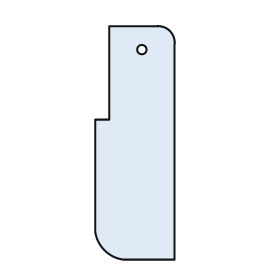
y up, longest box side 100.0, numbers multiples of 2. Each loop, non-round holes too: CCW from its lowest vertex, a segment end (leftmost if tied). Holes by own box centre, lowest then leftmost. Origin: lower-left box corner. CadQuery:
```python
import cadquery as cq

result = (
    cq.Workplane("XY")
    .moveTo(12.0, 0.0)
    .lineTo(34.0, 0.0)
    .lineTo(34.0, 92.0)
    .threePointArc((32.0, 98.0), (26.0, 100.0))
    .lineTo(6.0, 100.0)
    .lineTo(6.0, 60.0)
    .lineTo(0.0, 60.0)
    .lineTo(0.0, 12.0)
    .threePointArc((4.0, 4.0), (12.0, 0.0))
    .close()
    .moveTo(20.0, 90.0)
    .circle(2.0)
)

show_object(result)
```